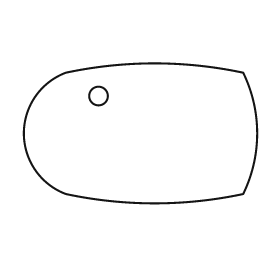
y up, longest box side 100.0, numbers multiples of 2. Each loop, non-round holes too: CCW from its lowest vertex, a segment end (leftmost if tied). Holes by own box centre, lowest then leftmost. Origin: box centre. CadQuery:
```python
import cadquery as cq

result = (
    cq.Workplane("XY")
    .moveTo(-32.0, -26.0)
    .threePointArc((6.0, -30.0), (44.0, -26.0))
    .threePointArc((50.0, 0.0), (44.0, 26.0))
    .threePointArc((6.0, 30.0), (-32.0, 26.0))
    .threePointArc((-50.0, 0.0), (-32.0, -26.0))
    .close()
    .moveTo(-18.0, 16.0)
    .circle(4.0)
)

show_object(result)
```